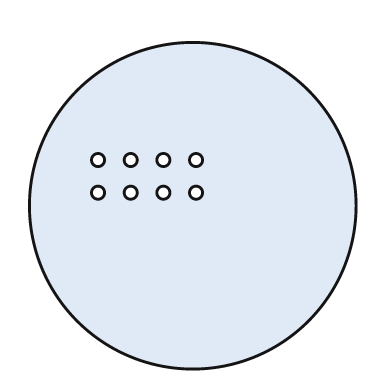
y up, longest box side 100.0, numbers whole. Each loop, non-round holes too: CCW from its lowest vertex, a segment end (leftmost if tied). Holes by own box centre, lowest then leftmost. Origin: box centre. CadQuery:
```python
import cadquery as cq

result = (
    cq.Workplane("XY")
    .moveTo(0.0, 0.0)
    .circle(50.0)
    .moveTo(-29.0, 4.0)
    .circle(2.0)
    .moveTo(-19.0, 4.0)
    .circle(2.0)
    .moveTo(-9.0, 4.0)
    .circle(2.0)
    .moveTo(1.0, 4.0)
    .circle(2.0)
    .moveTo(-29.0, 14.0)
    .circle(2.0)
    .moveTo(-19.0, 14.0)
    .circle(2.0)
    .moveTo(-9.0, 14.0)
    .circle(2.0)
    .moveTo(1.0, 14.0)
    .circle(2.0)
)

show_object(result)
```